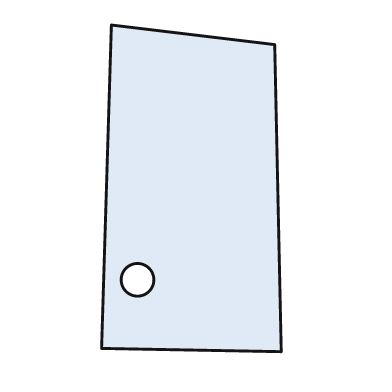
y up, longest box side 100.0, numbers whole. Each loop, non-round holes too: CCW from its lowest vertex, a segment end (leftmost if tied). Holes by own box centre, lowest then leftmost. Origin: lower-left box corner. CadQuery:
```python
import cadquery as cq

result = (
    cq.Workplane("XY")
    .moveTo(55.0, 0.0)
    .lineTo(53.0, 94.0)
    .lineTo(3.0, 100.0)
    .lineTo(0.0, 1.0)
    .close()
    .moveTo(11.0, 22.0)
    .circle(5.0)
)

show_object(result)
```